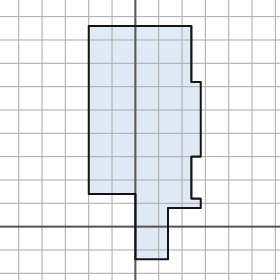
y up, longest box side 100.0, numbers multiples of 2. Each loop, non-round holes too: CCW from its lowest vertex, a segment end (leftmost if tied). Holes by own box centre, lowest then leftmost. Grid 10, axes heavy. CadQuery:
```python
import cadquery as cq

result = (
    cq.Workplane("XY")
    .moveTo(0.0, -14.0)
    .lineTo(14.0, -14.0)
    .lineTo(14.0, 8.0)
    .lineTo(28.0, 8.0)
    .lineTo(28.0, 12.0)
    .lineTo(24.0, 12.0)
    .lineTo(24.0, 30.0)
    .lineTo(28.0, 30.0)
    .lineTo(28.0, 62.0)
    .lineTo(24.0, 62.0)
    .lineTo(24.0, 86.0)
    .lineTo(-20.0, 86.0)
    .lineTo(-20.0, 14.0)
    .lineTo(0.0, 14.0)
    .close()
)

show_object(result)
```